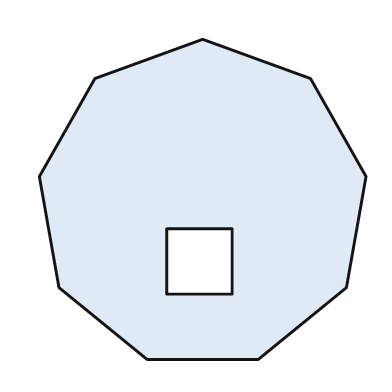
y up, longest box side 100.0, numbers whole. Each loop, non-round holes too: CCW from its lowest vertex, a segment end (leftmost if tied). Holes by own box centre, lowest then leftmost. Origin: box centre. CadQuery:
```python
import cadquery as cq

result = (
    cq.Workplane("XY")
    .moveTo(-17.0, -49.0)
    .lineTo(17.0, -49.0)
    .lineTo(44.0, -27.0)
    .lineTo(50.0, 7.0)
    .lineTo(33.0, 37.0)
    .lineTo(0.0, 49.0)
    .lineTo(-33.0, 37.0)
    .lineTo(-50.0, 7.0)
    .lineTo(-44.0, -27.0)
    .close()
    .moveTo(-11.0, -29.0)
    .lineTo(9.0, -29.0)
    .lineTo(9.0, -9.0)
    .lineTo(-11.0, -9.0)
    .close()
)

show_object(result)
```